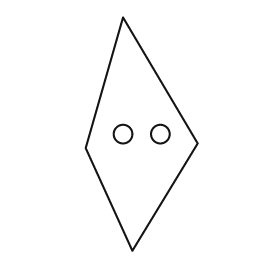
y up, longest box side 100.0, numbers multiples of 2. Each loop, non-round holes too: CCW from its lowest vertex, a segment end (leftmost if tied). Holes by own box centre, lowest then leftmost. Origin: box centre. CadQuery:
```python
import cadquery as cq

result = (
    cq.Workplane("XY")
    .moveTo(-4.0, -50.0)
    .lineTo(24.0, -4.0)
    .lineTo(-8.0, 50.0)
    .lineTo(-24.0, -6.0)
    .close()
    .moveTo(-8.0, 0.0)
    .circle(4.0)
    .moveTo(8.0, 0.0)
    .circle(4.0)
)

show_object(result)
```